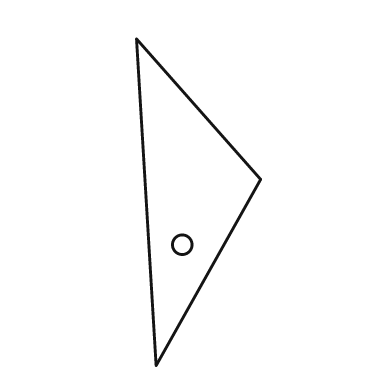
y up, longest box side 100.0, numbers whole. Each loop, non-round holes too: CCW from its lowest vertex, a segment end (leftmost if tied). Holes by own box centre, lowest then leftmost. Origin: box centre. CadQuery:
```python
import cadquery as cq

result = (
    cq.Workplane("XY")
    .moveTo(-13.0, -50.0)
    .lineTo(19.0, 7.0)
    .lineTo(-19.0, 50.0)
    .close()
    .moveTo(-5.0, -13.0)
    .circle(3.0)
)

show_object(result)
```